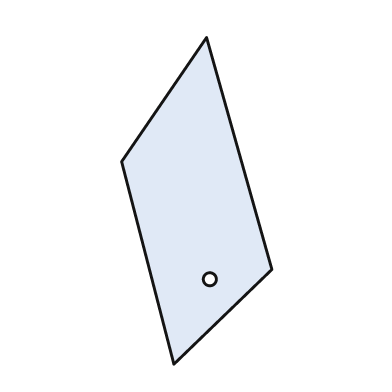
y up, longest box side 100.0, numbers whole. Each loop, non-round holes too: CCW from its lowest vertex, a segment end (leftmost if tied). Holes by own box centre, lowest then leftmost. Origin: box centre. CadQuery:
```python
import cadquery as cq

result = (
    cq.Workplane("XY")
    .moveTo(-7.0, -50.0)
    .lineTo(23.0, -21.0)
    .lineTo(3.0, 50.0)
    .lineTo(-23.0, 12.0)
    .close()
    .moveTo(4.0, -24.0)
    .circle(2.0)
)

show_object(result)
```